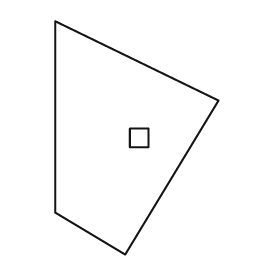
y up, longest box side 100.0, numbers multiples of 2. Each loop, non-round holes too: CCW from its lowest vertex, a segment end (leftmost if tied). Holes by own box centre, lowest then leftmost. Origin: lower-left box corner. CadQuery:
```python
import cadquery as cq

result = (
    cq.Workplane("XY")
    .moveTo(30.0, 0.0)
    .lineTo(70.0, 66.0)
    .lineTo(0.0, 100.0)
    .lineTo(0.0, 18.0)
    .close()
    .moveTo(32.0, 46.0)
    .lineTo(40.0, 46.0)
    .lineTo(40.0, 54.0)
    .lineTo(32.0, 54.0)
    .close()
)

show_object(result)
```